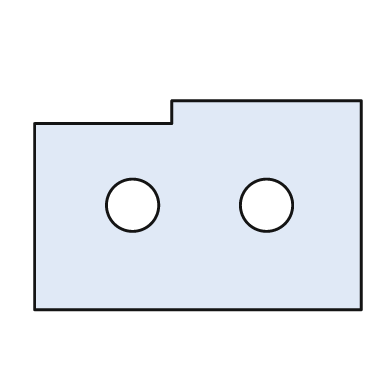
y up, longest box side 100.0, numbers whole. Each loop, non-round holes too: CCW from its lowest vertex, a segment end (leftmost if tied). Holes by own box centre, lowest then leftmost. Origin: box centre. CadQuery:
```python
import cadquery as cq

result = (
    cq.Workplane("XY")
    .moveTo(-50.0, -32.0)
    .lineTo(50.0, -32.0)
    .lineTo(50.0, 32.0)
    .lineTo(-8.0, 32.0)
    .lineTo(-8.0, 25.0)
    .lineTo(-50.0, 25.0)
    .close()
    .moveTo(-20.0, 0.0)
    .circle(8.0)
    .moveTo(21.0, 0.0)
    .circle(8.0)
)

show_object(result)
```